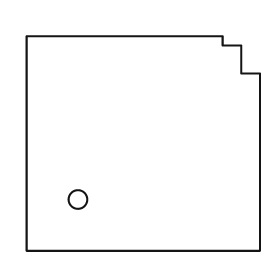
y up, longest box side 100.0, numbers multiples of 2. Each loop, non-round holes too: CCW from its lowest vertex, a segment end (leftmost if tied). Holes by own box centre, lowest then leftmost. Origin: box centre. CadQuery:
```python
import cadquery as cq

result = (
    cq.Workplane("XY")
    .moveTo(-50.0, -46.0)
    .lineTo(50.0, -46.0)
    .lineTo(50.0, 30.0)
    .lineTo(42.0, 30.0)
    .lineTo(42.0, 42.0)
    .lineTo(34.0, 42.0)
    .lineTo(34.0, 46.0)
    .lineTo(-50.0, 46.0)
    .close()
    .moveTo(-28.0, -24.0)
    .circle(4.0)
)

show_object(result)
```